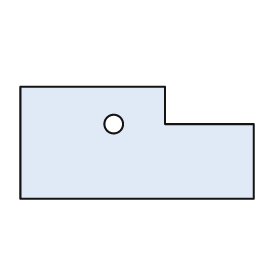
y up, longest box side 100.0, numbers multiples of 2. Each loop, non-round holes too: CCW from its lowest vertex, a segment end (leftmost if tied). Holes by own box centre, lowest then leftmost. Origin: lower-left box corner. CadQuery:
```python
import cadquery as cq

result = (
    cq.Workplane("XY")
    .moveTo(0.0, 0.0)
    .lineTo(100.0, 0.0)
    .lineTo(100.0, 32.0)
    .lineTo(62.0, 32.0)
    .lineTo(62.0, 48.0)
    .lineTo(0.0, 48.0)
    .close()
    .moveTo(40.0, 32.0)
    .circle(4.0)
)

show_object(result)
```